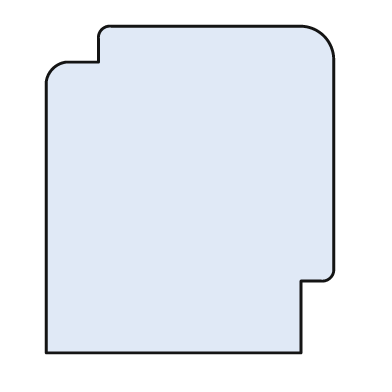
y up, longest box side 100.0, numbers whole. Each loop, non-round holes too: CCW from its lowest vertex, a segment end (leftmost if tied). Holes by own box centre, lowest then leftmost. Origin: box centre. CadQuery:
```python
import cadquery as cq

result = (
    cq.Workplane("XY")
    .moveTo(-44.0, -50.0)
    .lineTo(34.0, -50.0)
    .lineTo(34.0, -28.0)
    .lineTo(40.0, -28.0)
    .threePointArc((43.0, -27.0), (44.0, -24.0))
    .lineTo(44.0, 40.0)
    .threePointArc((41.0, 47.0), (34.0, 50.0))
    .lineTo(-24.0, 50.0)
    .threePointArc((-27.0, 49.0), (-28.0, 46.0))
    .lineTo(-28.0, 39.0)
    .lineTo(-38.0, 39.0)
    .threePointArc((-42.0, 37.0), (-44.0, 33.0))
    .close()
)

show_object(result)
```